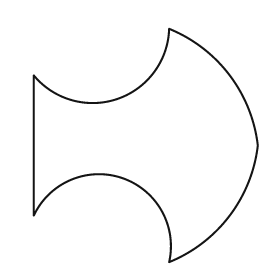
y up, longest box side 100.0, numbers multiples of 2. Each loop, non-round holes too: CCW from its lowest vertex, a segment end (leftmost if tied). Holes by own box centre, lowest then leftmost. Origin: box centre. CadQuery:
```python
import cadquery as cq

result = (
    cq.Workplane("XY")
    .moveTo(10.0, -50.0)
    .threePointArc((36.0, -30.0), (48.0, 0.0))
    .threePointArc((36.0, 30.0), (10.0, 50.0))
    .threePointArc((-12.0, 20.0), (-48.0, 30.0))
    .lineTo(-48.0, -30.0)
    .threePointArc((-10.0, -14.0), (10.0, -50.0))
    .close()
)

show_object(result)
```